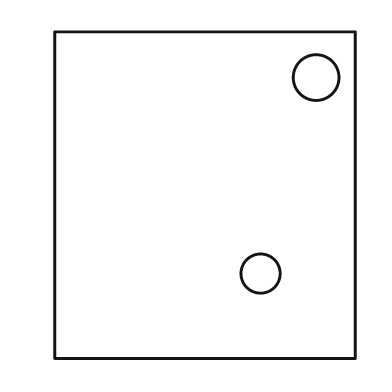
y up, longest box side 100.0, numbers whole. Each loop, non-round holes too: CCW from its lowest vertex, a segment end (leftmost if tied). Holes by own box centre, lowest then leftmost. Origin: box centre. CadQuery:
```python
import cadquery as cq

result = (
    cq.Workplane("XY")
    .moveTo(-46.0, -50.0)
    .lineTo(46.0, -50.0)
    .lineTo(46.0, 50.0)
    .lineTo(-46.0, 50.0)
    .close()
    .moveTo(17.0, -24.0)
    .circle(6.0)
    .moveTo(34.0, 36.0)
    .circle(7.0)
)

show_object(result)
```